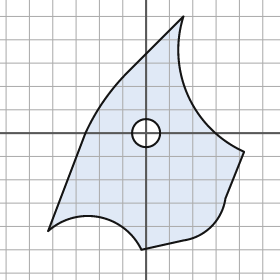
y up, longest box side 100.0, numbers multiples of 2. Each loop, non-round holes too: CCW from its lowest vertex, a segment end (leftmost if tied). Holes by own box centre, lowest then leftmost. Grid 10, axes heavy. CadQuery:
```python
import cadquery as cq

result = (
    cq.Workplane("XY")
    .moveTo(-2.0, -50.0)
    .lineTo(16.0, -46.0)
    .threePointArc((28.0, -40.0), (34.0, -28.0))
    .lineTo(42.0, -8.0)
    .threePointArc((18.0, 16.0), (16.0, 50.0))
    .lineTo(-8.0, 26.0)
    .threePointArc((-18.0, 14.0), (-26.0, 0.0))
    .lineTo(-42.0, -42.0)
    .threePointArc((-20.0, -36.0), (-2.0, -50.0))
    .close()
    .moveTo(0.0, 0.0)
    .circle(6.0)
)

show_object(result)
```